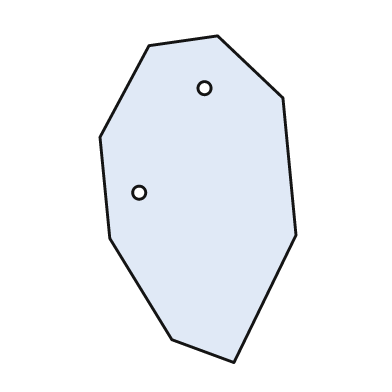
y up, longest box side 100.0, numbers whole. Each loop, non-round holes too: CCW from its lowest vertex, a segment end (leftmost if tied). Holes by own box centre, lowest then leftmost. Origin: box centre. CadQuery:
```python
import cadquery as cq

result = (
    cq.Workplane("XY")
    .moveTo(11.0, -50.0)
    .lineTo(30.0, -11.0)
    .lineTo(26.0, 31.0)
    .lineTo(6.0, 50.0)
    .lineTo(-15.0, 47.0)
    .lineTo(-30.0, 19.0)
    .lineTo(-27.0, -12.0)
    .lineTo(-8.0, -43.0)
    .close()
    .moveTo(-18.0, 2.0)
    .circle(2.0)
    .moveTo(2.0, 34.0)
    .circle(2.0)
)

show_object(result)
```